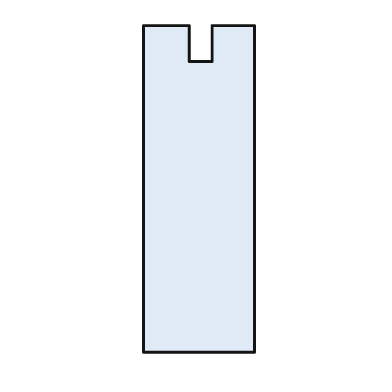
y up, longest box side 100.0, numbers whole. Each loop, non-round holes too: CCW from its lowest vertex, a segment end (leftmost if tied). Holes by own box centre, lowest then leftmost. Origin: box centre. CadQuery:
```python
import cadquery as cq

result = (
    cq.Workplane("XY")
    .moveTo(-17.0, -50.0)
    .lineTo(17.0, -50.0)
    .lineTo(17.0, 50.0)
    .lineTo(4.0, 50.0)
    .lineTo(4.0, 39.0)
    .lineTo(-3.0, 39.0)
    .lineTo(-3.0, 50.0)
    .lineTo(-17.0, 50.0)
    .close()
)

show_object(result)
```